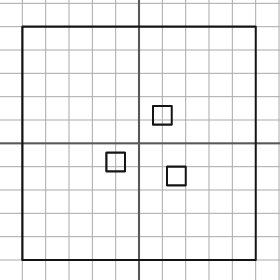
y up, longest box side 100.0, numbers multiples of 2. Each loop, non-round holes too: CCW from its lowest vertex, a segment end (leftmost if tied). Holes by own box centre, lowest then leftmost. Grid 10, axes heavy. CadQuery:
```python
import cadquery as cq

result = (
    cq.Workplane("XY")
    .moveTo(-50.0, -50.0)
    .lineTo(50.0, -50.0)
    .lineTo(50.0, 50.0)
    .lineTo(-50.0, 50.0)
    .close()
    .moveTo(12.0, -18.0)
    .lineTo(20.0, -18.0)
    .lineTo(20.0, -10.0)
    .lineTo(12.0, -10.0)
    .close()
    .moveTo(-14.0, -12.0)
    .lineTo(-6.0, -12.0)
    .lineTo(-6.0, -4.0)
    .lineTo(-14.0, -4.0)
    .close()
    .moveTo(6.0, 8.0)
    .lineTo(14.0, 8.0)
    .lineTo(14.0, 16.0)
    .lineTo(6.0, 16.0)
    .close()
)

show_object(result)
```